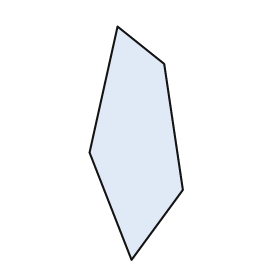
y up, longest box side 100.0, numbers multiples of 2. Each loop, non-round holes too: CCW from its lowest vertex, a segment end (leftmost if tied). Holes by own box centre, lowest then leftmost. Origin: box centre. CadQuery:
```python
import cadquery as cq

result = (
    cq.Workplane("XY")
    .moveTo(-2.0, -50.0)
    .lineTo(20.0, -20.0)
    .lineTo(12.0, 34.0)
    .lineTo(-8.0, 50.0)
    .lineTo(-20.0, -4.0)
    .close()
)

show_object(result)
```